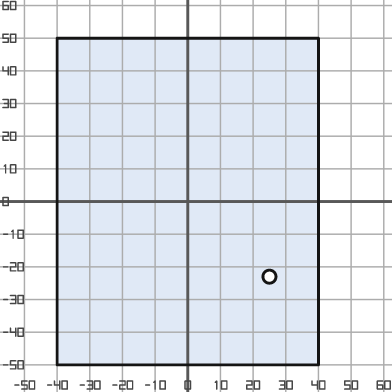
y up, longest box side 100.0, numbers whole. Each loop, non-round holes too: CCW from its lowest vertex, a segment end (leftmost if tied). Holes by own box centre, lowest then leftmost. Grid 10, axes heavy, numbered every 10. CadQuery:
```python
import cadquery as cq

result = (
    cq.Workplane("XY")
    .moveTo(-40.0, -50.0)
    .lineTo(40.0, -50.0)
    .lineTo(40.0, 50.0)
    .lineTo(-40.0, 50.0)
    .close()
    .moveTo(25.0, -23.0)
    .circle(2.0)
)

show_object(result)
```